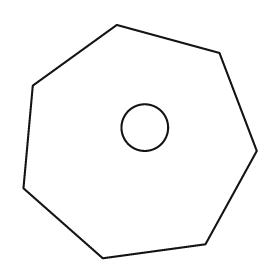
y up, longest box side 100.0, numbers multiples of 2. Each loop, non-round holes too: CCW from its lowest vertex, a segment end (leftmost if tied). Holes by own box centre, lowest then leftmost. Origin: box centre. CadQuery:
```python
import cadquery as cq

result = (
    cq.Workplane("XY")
    .moveTo(-16.0, -50.0)
    .lineTo(28.0, -44.0)
    .lineTo(50.0, -4.0)
    .lineTo(34.0, 38.0)
    .lineTo(-10.0, 50.0)
    .lineTo(-46.0, 24.0)
    .lineTo(-50.0, -20.0)
    .close()
    .moveTo(2.0, 6.0)
    .circle(10.0)
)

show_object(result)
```